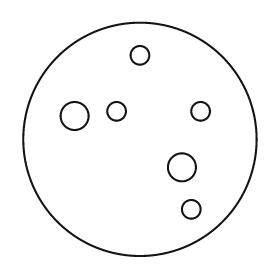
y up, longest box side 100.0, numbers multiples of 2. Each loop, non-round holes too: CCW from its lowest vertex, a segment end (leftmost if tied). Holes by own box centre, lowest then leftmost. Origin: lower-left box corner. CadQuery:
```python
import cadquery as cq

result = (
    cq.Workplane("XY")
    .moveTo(50.0, 50.0)
    .circle(50.0)
    .moveTo(72.0, 20.0)
    .circle(4.0)
    .moveTo(68.0, 38.0)
    .circle(6.0)
    .moveTo(22.0, 60.0)
    .circle(6.0)
    .moveTo(40.0, 62.0)
    .circle(4.0)
    .moveTo(76.0, 62.0)
    .circle(4.0)
    .moveTo(50.0, 86.0)
    .circle(4.0)
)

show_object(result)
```